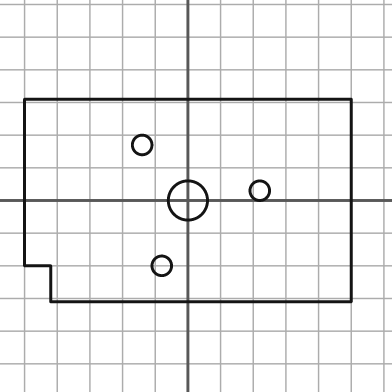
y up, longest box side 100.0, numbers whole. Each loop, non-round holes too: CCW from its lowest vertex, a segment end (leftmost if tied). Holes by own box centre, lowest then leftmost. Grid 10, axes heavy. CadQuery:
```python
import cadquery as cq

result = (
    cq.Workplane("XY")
    .moveTo(-42.0, -31.0)
    .lineTo(50.0, -31.0)
    .lineTo(50.0, 31.0)
    .lineTo(-50.0, 31.0)
    .lineTo(-50.0, -20.0)
    .lineTo(-42.0, -20.0)
    .close()
    .moveTo(-8.0, -20.0)
    .circle(3.0)
    .moveTo(0.0, 0.0)
    .circle(6.0)
    .moveTo(22.0, 3.0)
    .circle(3.0)
    .moveTo(-14.0, 17.0)
    .circle(3.0)
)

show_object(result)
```